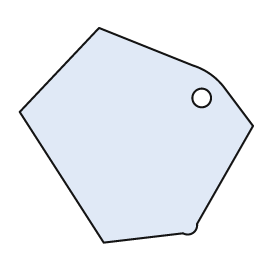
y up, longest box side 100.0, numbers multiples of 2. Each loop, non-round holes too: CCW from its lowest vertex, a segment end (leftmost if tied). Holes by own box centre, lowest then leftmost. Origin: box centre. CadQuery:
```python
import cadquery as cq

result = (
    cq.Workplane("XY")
    .moveTo(-14.0, -46.0)
    .lineTo(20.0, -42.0)
    .threePointArc((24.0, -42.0), (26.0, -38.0))
    .lineTo(50.0, 4.0)
    .lineTo(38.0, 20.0)
    .threePointArc((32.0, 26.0), (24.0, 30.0))
    .lineTo(-16.0, 46.0)
    .lineTo(-50.0, 10.0)
    .close()
    .moveTo(28.0, 16.0)
    .circle(4.0)
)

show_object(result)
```